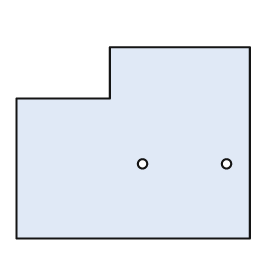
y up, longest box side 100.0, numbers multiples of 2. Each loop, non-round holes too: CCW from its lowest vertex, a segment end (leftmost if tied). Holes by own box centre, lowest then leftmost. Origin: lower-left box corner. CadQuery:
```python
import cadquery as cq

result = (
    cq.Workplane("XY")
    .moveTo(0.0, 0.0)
    .lineTo(100.0, 0.0)
    .lineTo(100.0, 82.0)
    .lineTo(40.0, 82.0)
    .lineTo(40.0, 60.0)
    .lineTo(0.0, 60.0)
    .close()
    .moveTo(54.0, 32.0)
    .circle(2.0)
    .moveTo(90.0, 32.0)
    .circle(2.0)
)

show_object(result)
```